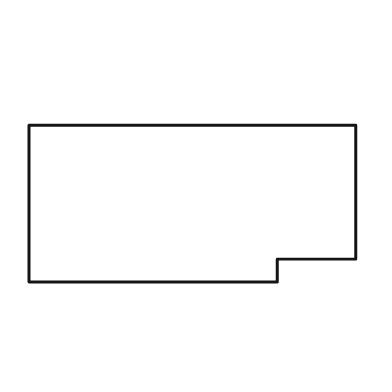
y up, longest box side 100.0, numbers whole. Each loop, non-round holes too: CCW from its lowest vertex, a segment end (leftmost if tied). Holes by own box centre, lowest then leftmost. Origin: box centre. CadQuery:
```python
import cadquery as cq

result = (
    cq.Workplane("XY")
    .moveTo(-50.0, -24.0)
    .lineTo(26.0, -24.0)
    .lineTo(26.0, -17.0)
    .lineTo(50.0, -17.0)
    .lineTo(50.0, 24.0)
    .lineTo(-50.0, 24.0)
    .close()
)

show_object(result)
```